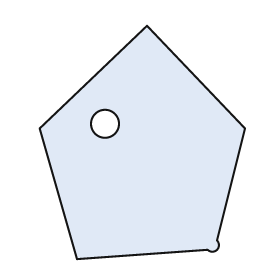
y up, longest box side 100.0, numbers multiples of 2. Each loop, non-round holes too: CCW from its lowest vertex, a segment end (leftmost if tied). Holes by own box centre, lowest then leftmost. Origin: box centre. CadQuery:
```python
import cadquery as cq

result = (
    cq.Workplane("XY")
    .moveTo(-28.0, -50.0)
    .lineTo(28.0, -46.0)
    .threePointArc((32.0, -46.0), (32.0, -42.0))
    .lineTo(44.0, 6.0)
    .lineTo(2.0, 50.0)
    .lineTo(-44.0, 6.0)
    .close()
    .moveTo(-16.0, 8.0)
    .circle(6.0)
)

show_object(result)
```